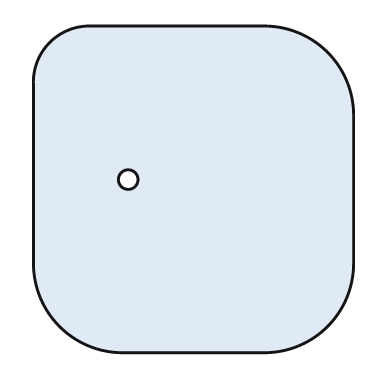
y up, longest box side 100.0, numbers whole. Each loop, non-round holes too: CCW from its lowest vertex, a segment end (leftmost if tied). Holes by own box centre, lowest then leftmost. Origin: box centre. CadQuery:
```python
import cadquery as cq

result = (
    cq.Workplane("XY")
    .moveTo(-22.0, -50.0)
    .lineTo(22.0, -50.0)
    .threePointArc((41.0, -42.0), (49.0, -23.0))
    .lineTo(49.0, 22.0)
    .threePointArc((41.0, 42.0), (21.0, 50.0))
    .lineTo(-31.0, 50.0)
    .threePointArc((-44.0, 45.0), (-49.0, 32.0))
    .lineTo(-49.0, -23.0)
    .threePointArc((-41.0, -42.0), (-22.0, -50.0))
    .close()
    .moveTo(-20.0, 3.0)
    .circle(3.0)
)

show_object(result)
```